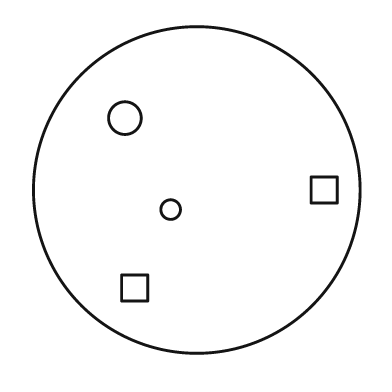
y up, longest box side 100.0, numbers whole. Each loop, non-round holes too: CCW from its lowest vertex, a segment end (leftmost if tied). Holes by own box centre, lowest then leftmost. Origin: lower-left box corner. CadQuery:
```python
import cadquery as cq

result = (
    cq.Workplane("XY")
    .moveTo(50.0, 50.0)
    .circle(50.0)
    .moveTo(27.0, 16.0)
    .lineTo(35.0, 16.0)
    .lineTo(35.0, 24.0)
    .lineTo(27.0, 24.0)
    .close()
    .moveTo(42.0, 44.0)
    .circle(3.0)
    .moveTo(85.0, 46.0)
    .lineTo(93.0, 46.0)
    .lineTo(93.0, 54.0)
    .lineTo(85.0, 54.0)
    .close()
    .moveTo(28.0, 72.0)
    .circle(5.0)
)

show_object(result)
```